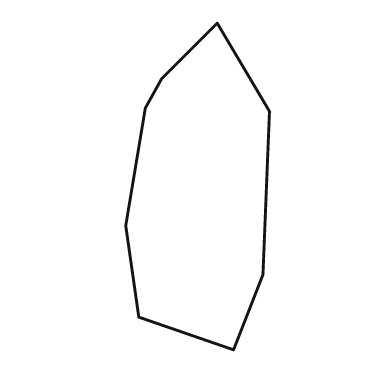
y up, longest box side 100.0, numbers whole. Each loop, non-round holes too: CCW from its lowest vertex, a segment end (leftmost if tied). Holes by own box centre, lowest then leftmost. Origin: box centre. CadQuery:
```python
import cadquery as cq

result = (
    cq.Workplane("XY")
    .moveTo(11.0, -50.0)
    .lineTo(20.0, -27.0)
    .lineTo(22.0, 23.0)
    .lineTo(6.0, 50.0)
    .lineTo(-11.0, 33.0)
    .lineTo(-16.0, 24.0)
    .lineTo(-22.0, -12.0)
    .lineTo(-18.0, -40.0)
    .close()
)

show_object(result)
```